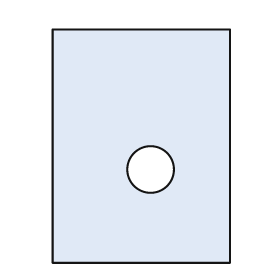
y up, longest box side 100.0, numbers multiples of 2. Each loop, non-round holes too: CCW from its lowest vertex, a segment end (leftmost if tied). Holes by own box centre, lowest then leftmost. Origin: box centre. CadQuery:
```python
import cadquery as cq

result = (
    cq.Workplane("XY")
    .moveTo(-38.0, -50.0)
    .lineTo(38.0, -50.0)
    .lineTo(38.0, 50.0)
    .lineTo(-38.0, 50.0)
    .close()
    .moveTo(4.0, -10.0)
    .circle(10.0)
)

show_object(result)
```